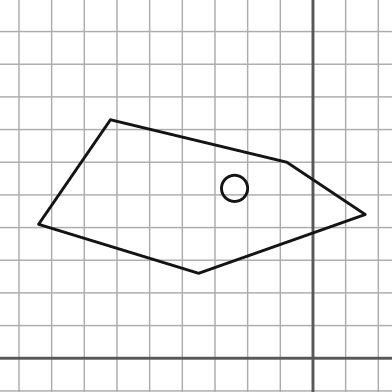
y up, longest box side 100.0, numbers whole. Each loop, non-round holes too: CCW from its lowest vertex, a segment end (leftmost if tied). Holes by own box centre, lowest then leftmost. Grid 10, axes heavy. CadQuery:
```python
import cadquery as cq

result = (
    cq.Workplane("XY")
    .moveTo(-35.0, 26.0)
    .lineTo(16.0, 44.0)
    .lineTo(-8.0, 60.0)
    .lineTo(-62.0, 73.0)
    .lineTo(-84.0, 41.0)
    .close()
    .moveTo(-24.0, 52.0)
    .circle(4.0)
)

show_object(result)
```